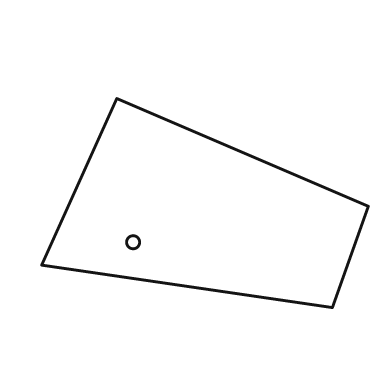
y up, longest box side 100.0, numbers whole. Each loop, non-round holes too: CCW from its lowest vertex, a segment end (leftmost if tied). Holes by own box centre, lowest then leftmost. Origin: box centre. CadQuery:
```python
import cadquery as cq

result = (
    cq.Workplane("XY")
    .moveTo(39.0, -32.0)
    .lineTo(50.0, -1.0)
    .lineTo(-27.0, 32.0)
    .lineTo(-50.0, -19.0)
    .close()
    .moveTo(-22.0, -12.0)
    .circle(2.0)
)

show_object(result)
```